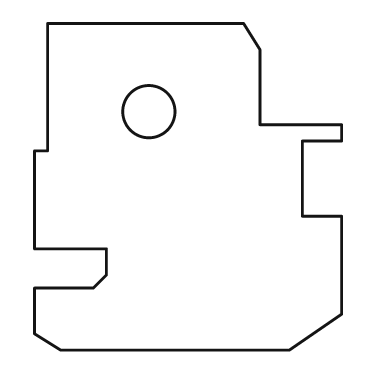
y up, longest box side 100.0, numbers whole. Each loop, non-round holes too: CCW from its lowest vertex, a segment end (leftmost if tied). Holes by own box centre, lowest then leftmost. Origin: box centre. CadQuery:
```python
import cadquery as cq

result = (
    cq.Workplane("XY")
    .moveTo(-39.0, -50.0)
    .lineTo(31.0, -50.0)
    .lineTo(47.0, -39.0)
    .lineTo(47.0, -9.0)
    .lineTo(35.0, -9.0)
    .lineTo(35.0, 14.0)
    .lineTo(47.0, 14.0)
    .lineTo(47.0, 19.0)
    .lineTo(22.0, 19.0)
    .lineTo(22.0, 42.0)
    .lineTo(17.0, 50.0)
    .lineTo(-43.0, 50.0)
    .lineTo(-43.0, 11.0)
    .lineTo(-47.0, 11.0)
    .lineTo(-47.0, -19.0)
    .lineTo(-25.0, -19.0)
    .lineTo(-25.0, -27.0)
    .lineTo(-29.0, -31.0)
    .lineTo(-47.0, -31.0)
    .lineTo(-47.0, -45.0)
    .close()
    .moveTo(-12.0, 23.0)
    .circle(8.0)
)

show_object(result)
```